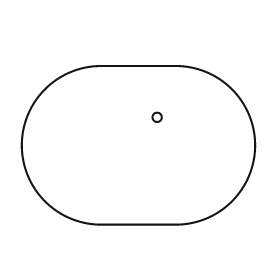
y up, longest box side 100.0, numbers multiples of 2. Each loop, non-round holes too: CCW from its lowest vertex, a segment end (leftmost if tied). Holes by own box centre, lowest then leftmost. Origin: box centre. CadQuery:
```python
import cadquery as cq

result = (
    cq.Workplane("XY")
    .moveTo(-16.0, -34.0)
    .lineTo(16.0, -34.0)
    .threePointArc((50.0, 0.0), (16.0, 34.0))
    .lineTo(-16.0, 34.0)
    .threePointArc((-50.0, 0.0), (-16.0, -34.0))
    .close()
    .moveTo(8.0, 12.0)
    .circle(2.0)
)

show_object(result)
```